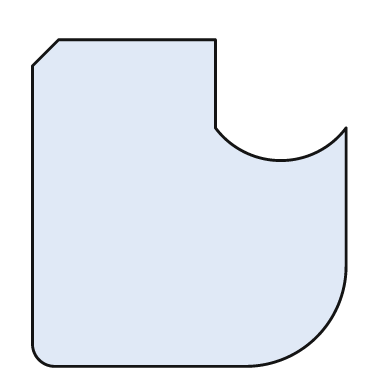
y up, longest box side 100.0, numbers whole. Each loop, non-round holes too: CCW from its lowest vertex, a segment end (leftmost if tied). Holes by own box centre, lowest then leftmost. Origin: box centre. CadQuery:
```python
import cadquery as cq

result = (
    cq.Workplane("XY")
    .moveTo(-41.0, -50.0)
    .lineTo(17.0, -50.0)
    .threePointArc((39.0, -41.0), (48.0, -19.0))
    .lineTo(48.0, 23.0)
    .threePointArc((28.0, 13.0), (8.0, 23.0))
    .lineTo(8.0, 50.0)
    .lineTo(-40.0, 50.0)
    .lineTo(-48.0, 42.0)
    .lineTo(-48.0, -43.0)
    .threePointArc((-46.0, -48.0), (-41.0, -50.0))
    .close()
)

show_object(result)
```